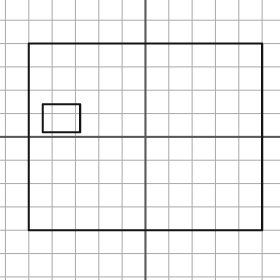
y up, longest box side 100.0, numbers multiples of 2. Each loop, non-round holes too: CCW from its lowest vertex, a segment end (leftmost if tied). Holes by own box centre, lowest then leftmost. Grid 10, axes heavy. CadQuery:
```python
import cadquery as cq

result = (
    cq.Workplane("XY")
    .moveTo(-50.0, -40.0)
    .lineTo(50.0, -40.0)
    .lineTo(50.0, 40.0)
    .lineTo(-50.0, 40.0)
    .close()
    .moveTo(-44.0, 2.0)
    .lineTo(-28.0, 2.0)
    .lineTo(-28.0, 14.0)
    .lineTo(-44.0, 14.0)
    .close()
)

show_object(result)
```